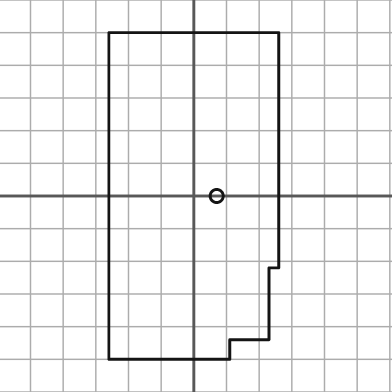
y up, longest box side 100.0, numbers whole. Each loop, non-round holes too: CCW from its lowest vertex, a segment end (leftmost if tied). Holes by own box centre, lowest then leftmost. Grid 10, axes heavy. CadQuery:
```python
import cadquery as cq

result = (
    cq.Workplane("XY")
    .moveTo(-26.0, -50.0)
    .lineTo(11.0, -50.0)
    .lineTo(11.0, -44.0)
    .lineTo(23.0, -44.0)
    .lineTo(23.0, -22.0)
    .lineTo(26.0, -22.0)
    .lineTo(26.0, 50.0)
    .lineTo(-26.0, 50.0)
    .close()
    .moveTo(7.0, 0.0)
    .circle(2.0)
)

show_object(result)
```